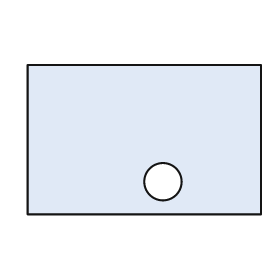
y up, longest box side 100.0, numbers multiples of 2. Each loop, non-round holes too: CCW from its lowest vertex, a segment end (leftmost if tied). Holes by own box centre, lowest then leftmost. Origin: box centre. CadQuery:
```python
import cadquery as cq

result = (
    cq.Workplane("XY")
    .moveTo(-50.0, -32.0)
    .lineTo(50.0, -32.0)
    .lineTo(50.0, 32.0)
    .lineTo(-50.0, 32.0)
    .close()
    .moveTo(8.0, -18.0)
    .circle(8.0)
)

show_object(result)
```